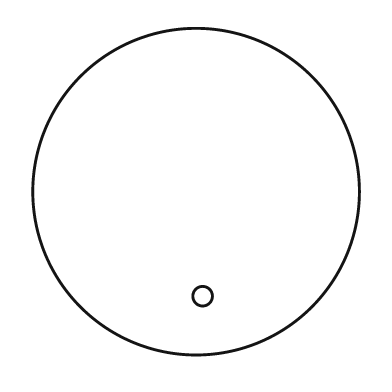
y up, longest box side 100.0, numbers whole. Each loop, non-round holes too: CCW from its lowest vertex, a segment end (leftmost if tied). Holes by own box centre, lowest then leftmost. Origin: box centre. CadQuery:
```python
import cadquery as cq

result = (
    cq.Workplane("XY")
    .moveTo(0.0, 0.0)
    .circle(50.0)
    .moveTo(2.0, -32.0)
    .circle(3.0)
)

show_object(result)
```